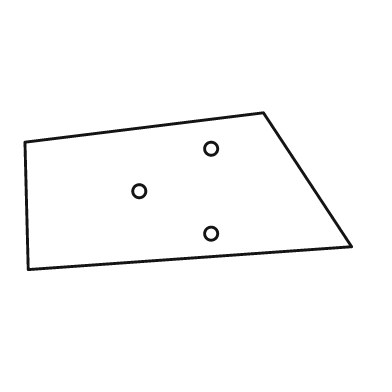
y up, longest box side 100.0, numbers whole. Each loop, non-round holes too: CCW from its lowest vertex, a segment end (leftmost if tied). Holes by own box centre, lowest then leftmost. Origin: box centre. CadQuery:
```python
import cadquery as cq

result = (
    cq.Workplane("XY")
    .moveTo(-49.0, -24.0)
    .lineTo(50.0, -17.0)
    .lineTo(23.0, 24.0)
    .lineTo(-50.0, 15.0)
    .close()
    .moveTo(7.0, -13.0)
    .circle(2.0)
    .moveTo(-15.0, 0.0)
    .circle(2.0)
    .moveTo(7.0, 13.0)
    .circle(2.0)
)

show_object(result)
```